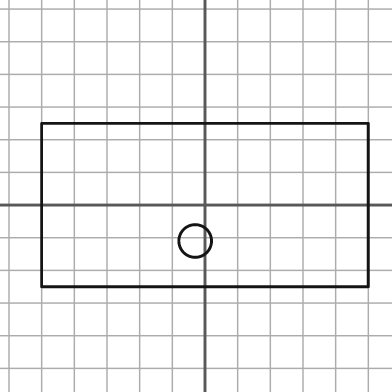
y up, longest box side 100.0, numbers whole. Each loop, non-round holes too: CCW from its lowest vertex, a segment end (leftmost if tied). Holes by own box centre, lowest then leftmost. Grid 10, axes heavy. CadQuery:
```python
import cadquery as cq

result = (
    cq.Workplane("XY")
    .moveTo(-50.0, -25.0)
    .lineTo(50.0, -25.0)
    .lineTo(50.0, 25.0)
    .lineTo(-50.0, 25.0)
    .close()
    .moveTo(-3.0, -11.0)
    .circle(5.0)
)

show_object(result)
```